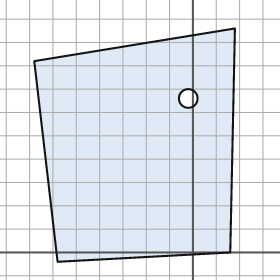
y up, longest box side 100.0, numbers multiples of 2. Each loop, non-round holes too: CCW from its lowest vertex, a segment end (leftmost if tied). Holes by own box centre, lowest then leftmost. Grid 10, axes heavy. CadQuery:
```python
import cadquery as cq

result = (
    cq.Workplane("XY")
    .moveTo(-58.0, -4.0)
    .lineTo(16.0, 0.0)
    .lineTo(18.0, 96.0)
    .lineTo(-68.0, 82.0)
    .close()
    .moveTo(-2.0, 66.0)
    .circle(4.0)
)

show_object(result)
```